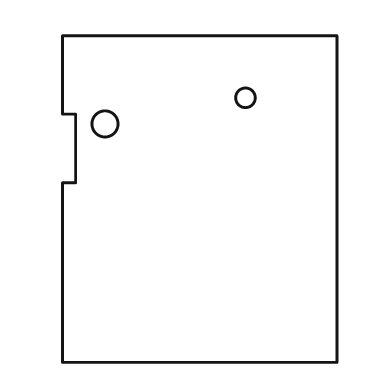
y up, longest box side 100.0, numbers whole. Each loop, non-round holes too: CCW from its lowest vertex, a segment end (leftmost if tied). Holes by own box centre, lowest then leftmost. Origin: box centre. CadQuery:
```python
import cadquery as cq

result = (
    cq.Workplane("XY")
    .moveTo(-42.0, -50.0)
    .lineTo(42.0, -50.0)
    .lineTo(42.0, 50.0)
    .lineTo(-42.0, 50.0)
    .lineTo(-42.0, 26.0)
    .lineTo(-38.0, 26.0)
    .lineTo(-38.0, 5.0)
    .lineTo(-42.0, 5.0)
    .close()
    .moveTo(-29.0, 23.0)
    .circle(4.0)
    .moveTo(14.0, 31.0)
    .circle(3.0)
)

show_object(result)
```